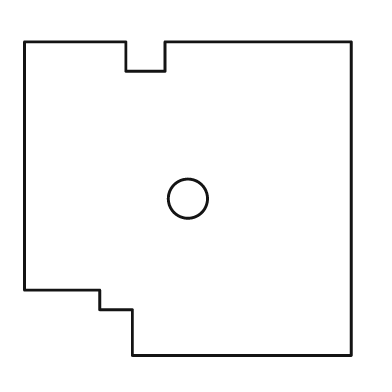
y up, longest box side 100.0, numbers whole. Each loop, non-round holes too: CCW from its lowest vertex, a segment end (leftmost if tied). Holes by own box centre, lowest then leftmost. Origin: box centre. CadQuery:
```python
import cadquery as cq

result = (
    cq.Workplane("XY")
    .moveTo(-17.0, -48.0)
    .lineTo(50.0, -48.0)
    .lineTo(50.0, 48.0)
    .lineTo(-7.0, 48.0)
    .lineTo(-7.0, 39.0)
    .lineTo(-19.0, 39.0)
    .lineTo(-19.0, 48.0)
    .lineTo(-50.0, 48.0)
    .lineTo(-50.0, -28.0)
    .lineTo(-27.0, -28.0)
    .lineTo(-27.0, -34.0)
    .lineTo(-17.0, -34.0)
    .close()
    .moveTo(0.0, 0.0)
    .circle(6.0)
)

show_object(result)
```